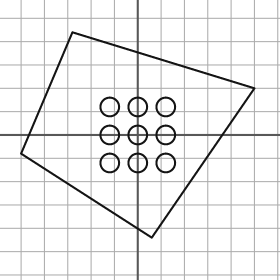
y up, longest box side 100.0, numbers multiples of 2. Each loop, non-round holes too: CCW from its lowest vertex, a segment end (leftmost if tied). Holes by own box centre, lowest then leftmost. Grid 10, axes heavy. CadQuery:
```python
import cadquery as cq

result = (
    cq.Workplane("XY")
    .moveTo(6.0, -44.0)
    .lineTo(50.0, 20.0)
    .lineTo(-28.0, 44.0)
    .lineTo(-50.0, -8.0)
    .close()
    .moveTo(-12.0, -12.0)
    .circle(4.0)
    .moveTo(0.0, -12.0)
    .circle(4.0)
    .moveTo(12.0, -12.0)
    .circle(4.0)
    .moveTo(-12.0, 0.0)
    .circle(4.0)
    .moveTo(0.0, 0.0)
    .circle(4.0)
    .moveTo(12.0, 0.0)
    .circle(4.0)
    .moveTo(-12.0, 12.0)
    .circle(4.0)
    .moveTo(0.0, 12.0)
    .circle(4.0)
    .moveTo(12.0, 12.0)
    .circle(4.0)
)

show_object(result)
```